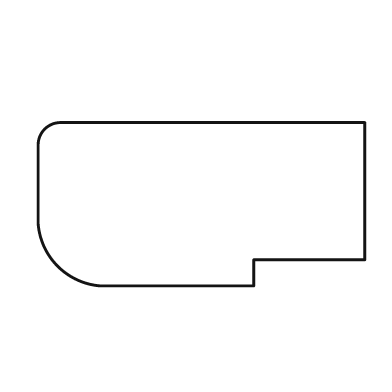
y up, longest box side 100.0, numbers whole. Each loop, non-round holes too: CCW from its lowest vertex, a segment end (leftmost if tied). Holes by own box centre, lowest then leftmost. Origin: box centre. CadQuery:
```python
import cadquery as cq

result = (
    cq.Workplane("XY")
    .moveTo(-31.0, -25.0)
    .lineTo(16.0, -25.0)
    .lineTo(16.0, -17.0)
    .lineTo(50.0, -17.0)
    .lineTo(50.0, 25.0)
    .lineTo(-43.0, 25.0)
    .threePointArc((-48.0, 23.0), (-50.0, 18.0))
    .lineTo(-50.0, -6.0)
    .threePointArc((-44.0, -19.0), (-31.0, -25.0))
    .close()
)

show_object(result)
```